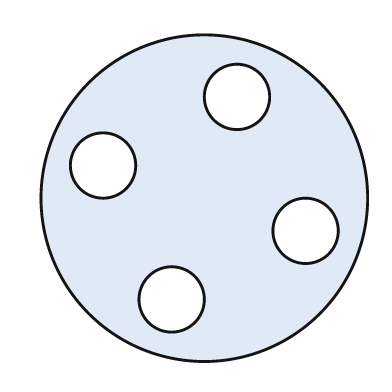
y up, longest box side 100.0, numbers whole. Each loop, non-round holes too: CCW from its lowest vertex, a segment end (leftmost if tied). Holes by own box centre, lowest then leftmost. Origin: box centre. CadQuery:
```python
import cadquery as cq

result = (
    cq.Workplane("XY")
    .moveTo(0.0, 0.0)
    .circle(50.0)
    .moveTo(-10.0, -31.0)
    .circle(10.0)
    .moveTo(31.0, -10.0)
    .circle(10.0)
    .moveTo(-31.0, 10.0)
    .circle(10.0)
    .moveTo(10.0, 31.0)
    .circle(10.0)
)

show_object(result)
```